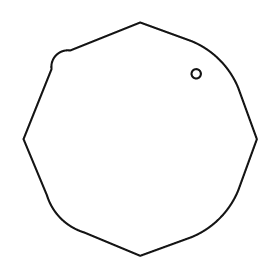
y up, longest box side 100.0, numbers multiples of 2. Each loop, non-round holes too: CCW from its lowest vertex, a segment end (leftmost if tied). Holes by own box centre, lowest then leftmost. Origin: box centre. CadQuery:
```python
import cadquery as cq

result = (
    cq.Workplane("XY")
    .moveTo(0.0, -50.0)
    .lineTo(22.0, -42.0)
    .threePointArc((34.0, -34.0), (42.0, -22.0))
    .lineTo(50.0, 0.0)
    .lineTo(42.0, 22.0)
    .threePointArc((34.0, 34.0), (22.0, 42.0))
    .lineTo(0.0, 50.0)
    .lineTo(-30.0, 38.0)
    .threePointArc((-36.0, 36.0), (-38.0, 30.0))
    .lineTo(-50.0, 0.0)
    .lineTo(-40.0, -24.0)
    .threePointArc((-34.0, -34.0), (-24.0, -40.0))
    .close()
    .moveTo(24.0, 28.0)
    .circle(2.0)
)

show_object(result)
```